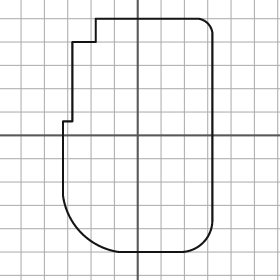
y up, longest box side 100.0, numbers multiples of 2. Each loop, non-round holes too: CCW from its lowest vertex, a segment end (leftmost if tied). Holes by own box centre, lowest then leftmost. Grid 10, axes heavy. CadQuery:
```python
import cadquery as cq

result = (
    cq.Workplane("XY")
    .moveTo(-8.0, -50.0)
    .lineTo(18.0, -50.0)
    .threePointArc((28.0, -46.0), (32.0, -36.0))
    .lineTo(32.0, 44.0)
    .threePointArc((30.0, 48.0), (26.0, 50.0))
    .lineTo(-18.0, 50.0)
    .lineTo(-18.0, 40.0)
    .lineTo(-28.0, 40.0)
    .lineTo(-28.0, 6.0)
    .lineTo(-32.0, 6.0)
    .lineTo(-32.0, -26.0)
    .threePointArc((-24.0, -42.0), (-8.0, -50.0))
    .close()
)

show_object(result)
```